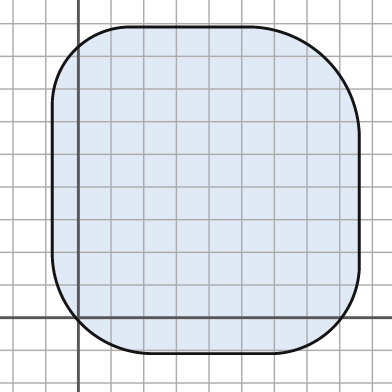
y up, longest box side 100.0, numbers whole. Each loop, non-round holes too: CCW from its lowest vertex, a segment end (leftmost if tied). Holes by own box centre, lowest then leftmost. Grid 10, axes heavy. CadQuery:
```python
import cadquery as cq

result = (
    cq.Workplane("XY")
    .moveTo(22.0, -11.0)
    .lineTo(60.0, -11.0)
    .threePointArc((78.0, -3.0), (86.0, 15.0))
    .lineTo(86.0, 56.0)
    .threePointArc((76.0, 79.0), (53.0, 89.0))
    .lineTo(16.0, 89.0)
    .threePointArc((-1.0, 82.0), (-8.0, 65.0))
    .lineTo(-8.0, 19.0)
    .threePointArc((1.0, -2.0), (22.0, -11.0))
    .close()
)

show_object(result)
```